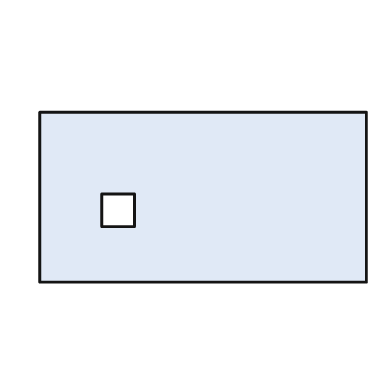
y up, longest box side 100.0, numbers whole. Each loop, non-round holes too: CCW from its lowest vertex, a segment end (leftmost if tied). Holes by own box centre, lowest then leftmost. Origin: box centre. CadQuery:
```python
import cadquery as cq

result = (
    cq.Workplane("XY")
    .moveTo(-50.0, -26.0)
    .lineTo(50.0, -26.0)
    .lineTo(50.0, 26.0)
    .lineTo(-50.0, 26.0)
    .close()
    .moveTo(-31.0, -9.0)
    .lineTo(-21.0, -9.0)
    .lineTo(-21.0, 1.0)
    .lineTo(-31.0, 1.0)
    .close()
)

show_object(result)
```